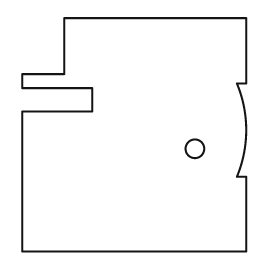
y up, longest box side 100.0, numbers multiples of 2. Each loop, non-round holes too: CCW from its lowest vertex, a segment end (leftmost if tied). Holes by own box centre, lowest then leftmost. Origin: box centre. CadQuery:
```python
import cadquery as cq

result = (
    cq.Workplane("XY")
    .moveTo(-48.0, -50.0)
    .lineTo(48.0, -50.0)
    .lineTo(48.0, -18.0)
    .lineTo(44.0, -18.0)
    .threePointArc((48.0, 2.0), (44.0, 22.0))
    .lineTo(48.0, 22.0)
    .lineTo(48.0, 50.0)
    .lineTo(-30.0, 50.0)
    .lineTo(-30.0, 26.0)
    .lineTo(-48.0, 26.0)
    .lineTo(-48.0, 20.0)
    .lineTo(-18.0, 20.0)
    .lineTo(-18.0, 10.0)
    .lineTo(-48.0, 10.0)
    .close()
    .moveTo(26.0, -6.0)
    .circle(4.0)
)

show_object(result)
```